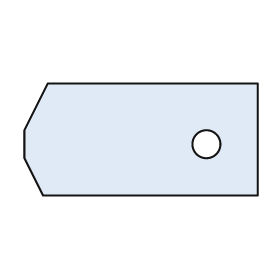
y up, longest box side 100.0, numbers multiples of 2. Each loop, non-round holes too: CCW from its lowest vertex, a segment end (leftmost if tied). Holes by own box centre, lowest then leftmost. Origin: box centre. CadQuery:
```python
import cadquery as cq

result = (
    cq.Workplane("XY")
    .moveTo(-42.0, -24.0)
    .lineTo(50.0, -24.0)
    .lineTo(50.0, 24.0)
    .lineTo(-40.0, 24.0)
    .lineTo(-50.0, 4.0)
    .lineTo(-50.0, -8.0)
    .close()
    .moveTo(28.0, -2.0)
    .circle(6.0)
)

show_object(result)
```